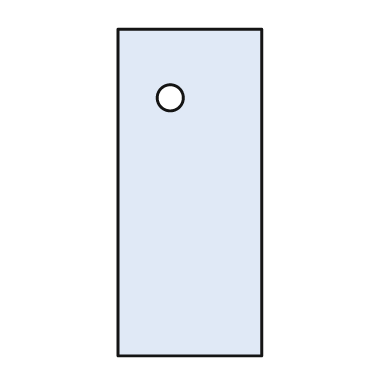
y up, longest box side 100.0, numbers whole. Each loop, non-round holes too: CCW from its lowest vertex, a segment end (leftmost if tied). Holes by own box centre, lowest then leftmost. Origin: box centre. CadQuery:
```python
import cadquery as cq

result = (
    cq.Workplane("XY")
    .moveTo(-22.0, -50.0)
    .lineTo(22.0, -50.0)
    .lineTo(22.0, 50.0)
    .lineTo(-22.0, 50.0)
    .close()
    .moveTo(-6.0, 29.0)
    .circle(4.0)
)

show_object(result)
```